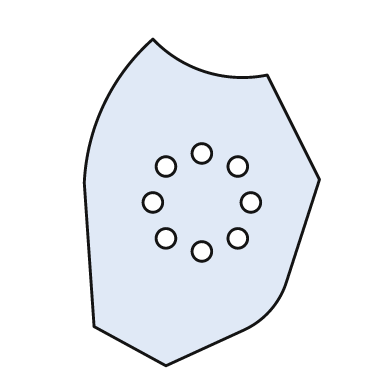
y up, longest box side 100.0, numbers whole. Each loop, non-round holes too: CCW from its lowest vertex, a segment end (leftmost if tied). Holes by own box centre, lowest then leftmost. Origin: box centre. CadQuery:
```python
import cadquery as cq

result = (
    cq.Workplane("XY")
    .moveTo(-11.0, -50.0)
    .lineTo(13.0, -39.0)
    .threePointArc((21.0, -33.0), (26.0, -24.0))
    .lineTo(36.0, 7.0)
    .lineTo(20.0, 39.0)
    .threePointArc((1.0, 40.0), (-15.0, 50.0))
    .threePointArc((-30.0, 30.0), (-36.0, 6.0))
    .lineTo(-33.0, -38.0)
    .close()
    .moveTo(0.0, -15.0)
    .circle(3.0)
    .moveTo(-11.0, -11.0)
    .circle(3.0)
    .moveTo(11.0, -11.0)
    .circle(3.0)
    .moveTo(-15.0, 0.0)
    .circle(3.0)
    .moveTo(15.0, 0.0)
    .circle(3.0)
    .moveTo(-11.0, 11.0)
    .circle(3.0)
    .moveTo(11.0, 11.0)
    .circle(3.0)
    .moveTo(0.0, 15.0)
    .circle(3.0)
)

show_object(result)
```